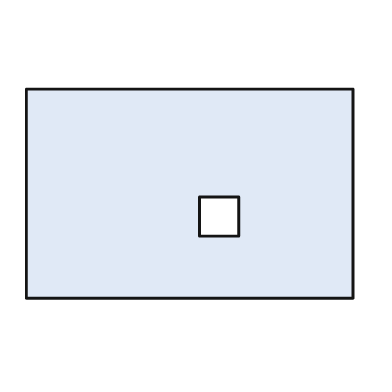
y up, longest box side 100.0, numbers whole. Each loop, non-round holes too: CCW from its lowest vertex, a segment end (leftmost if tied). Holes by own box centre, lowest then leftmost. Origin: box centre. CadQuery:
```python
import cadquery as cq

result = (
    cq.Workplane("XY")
    .moveTo(-50.0, -32.0)
    .lineTo(50.0, -32.0)
    .lineTo(50.0, 32.0)
    .lineTo(-50.0, 32.0)
    .close()
    .moveTo(3.0, -13.0)
    .lineTo(15.0, -13.0)
    .lineTo(15.0, -1.0)
    .lineTo(3.0, -1.0)
    .close()
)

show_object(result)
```